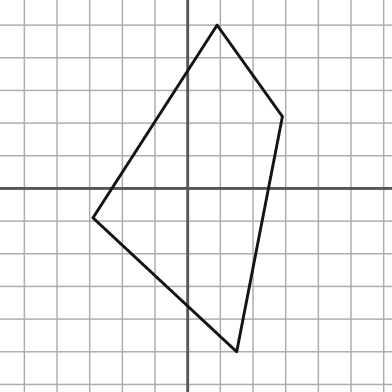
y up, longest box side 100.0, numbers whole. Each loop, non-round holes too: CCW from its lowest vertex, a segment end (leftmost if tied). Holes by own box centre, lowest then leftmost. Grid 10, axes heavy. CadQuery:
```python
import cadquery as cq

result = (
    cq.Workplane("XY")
    .moveTo(15.0, -50.0)
    .lineTo(29.0, 22.0)
    .lineTo(9.0, 50.0)
    .lineTo(-29.0, -9.0)
    .close()
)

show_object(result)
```